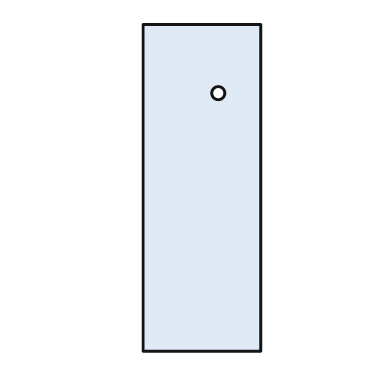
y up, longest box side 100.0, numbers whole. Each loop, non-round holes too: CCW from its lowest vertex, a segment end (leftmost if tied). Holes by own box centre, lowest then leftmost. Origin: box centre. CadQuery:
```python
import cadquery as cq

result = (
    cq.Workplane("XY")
    .moveTo(-18.0, -50.0)
    .lineTo(18.0, -50.0)
    .lineTo(18.0, 50.0)
    .lineTo(-18.0, 50.0)
    .close()
    .moveTo(5.0, 29.0)
    .circle(2.0)
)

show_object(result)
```